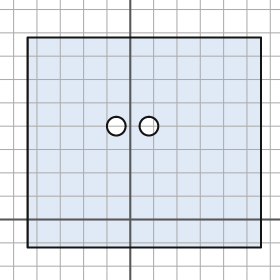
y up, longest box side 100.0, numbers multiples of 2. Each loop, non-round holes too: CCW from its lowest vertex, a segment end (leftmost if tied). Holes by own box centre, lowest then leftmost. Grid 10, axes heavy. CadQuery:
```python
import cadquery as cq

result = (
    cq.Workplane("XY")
    .moveTo(-44.0, -12.0)
    .lineTo(56.0, -12.0)
    .lineTo(56.0, 78.0)
    .lineTo(-44.0, 78.0)
    .close()
    .moveTo(-6.0, 40.0)
    .circle(4.0)
    .moveTo(8.0, 40.0)
    .circle(4.0)
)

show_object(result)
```